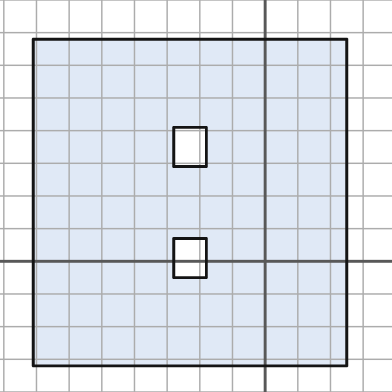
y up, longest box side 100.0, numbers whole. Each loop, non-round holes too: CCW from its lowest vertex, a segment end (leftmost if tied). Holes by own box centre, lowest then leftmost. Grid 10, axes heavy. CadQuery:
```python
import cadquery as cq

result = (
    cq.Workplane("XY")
    .moveTo(-71.0, -32.0)
    .lineTo(25.0, -32.0)
    .lineTo(25.0, 68.0)
    .lineTo(-71.0, 68.0)
    .close()
    .moveTo(-28.0, -5.0)
    .lineTo(-18.0, -5.0)
    .lineTo(-18.0, 7.0)
    .lineTo(-28.0, 7.0)
    .close()
    .moveTo(-28.0, 29.0)
    .lineTo(-18.0, 29.0)
    .lineTo(-18.0, 41.0)
    .lineTo(-28.0, 41.0)
    .close()
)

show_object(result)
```